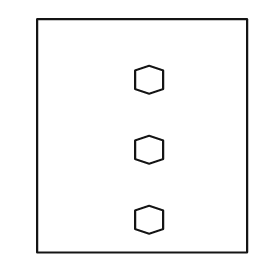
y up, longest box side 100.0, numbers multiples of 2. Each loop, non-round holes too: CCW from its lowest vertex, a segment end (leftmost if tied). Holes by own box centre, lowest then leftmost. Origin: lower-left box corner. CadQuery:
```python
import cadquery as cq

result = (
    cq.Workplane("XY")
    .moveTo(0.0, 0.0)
    .lineTo(90.0, 0.0)
    .lineTo(90.0, 100.0)
    .lineTo(0.0, 100.0)
    .close()
    .moveTo(48.0, 8.0)
    .lineTo(54.0, 10.0)
    .lineTo(54.0, 18.0)
    .lineTo(48.0, 20.0)
    .lineTo(42.0, 18.0)
    .lineTo(42.0, 10.0)
    .close()
    .moveTo(48.0, 38.0)
    .lineTo(54.0, 40.0)
    .lineTo(54.0, 48.0)
    .lineTo(48.0, 50.0)
    .lineTo(42.0, 48.0)
    .lineTo(42.0, 40.0)
    .close()
    .moveTo(48.0, 68.0)
    .lineTo(54.0, 70.0)
    .lineTo(54.0, 78.0)
    .lineTo(48.0, 80.0)
    .lineTo(42.0, 78.0)
    .lineTo(42.0, 70.0)
    .close()
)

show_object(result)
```